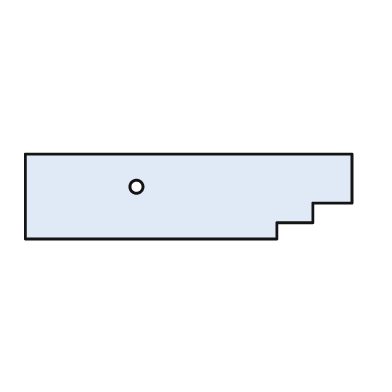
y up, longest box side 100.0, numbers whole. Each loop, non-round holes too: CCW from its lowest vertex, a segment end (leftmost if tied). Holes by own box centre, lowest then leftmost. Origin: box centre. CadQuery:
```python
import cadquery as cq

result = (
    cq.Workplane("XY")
    .moveTo(-50.0, -13.0)
    .lineTo(27.0, -13.0)
    .lineTo(27.0, -8.0)
    .lineTo(38.0, -8.0)
    .lineTo(38.0, -2.0)
    .lineTo(50.0, -2.0)
    .lineTo(50.0, 13.0)
    .lineTo(-50.0, 13.0)
    .close()
    .moveTo(-16.0, 3.0)
    .circle(2.0)
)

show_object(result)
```